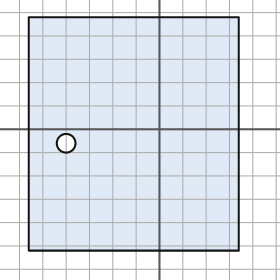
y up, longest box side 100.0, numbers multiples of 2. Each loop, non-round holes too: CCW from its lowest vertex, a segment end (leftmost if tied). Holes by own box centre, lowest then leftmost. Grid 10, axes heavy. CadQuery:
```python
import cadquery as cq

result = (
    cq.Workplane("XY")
    .moveTo(-56.0, -52.0)
    .lineTo(34.0, -52.0)
    .lineTo(34.0, 48.0)
    .lineTo(-56.0, 48.0)
    .close()
    .moveTo(-40.0, -6.0)
    .circle(4.0)
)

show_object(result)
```